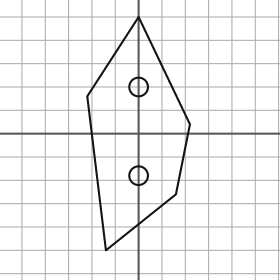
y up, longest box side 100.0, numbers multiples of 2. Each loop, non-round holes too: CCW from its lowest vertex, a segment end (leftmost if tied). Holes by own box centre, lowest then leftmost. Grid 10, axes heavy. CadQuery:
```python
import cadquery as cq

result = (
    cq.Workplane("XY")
    .moveTo(-14.0, -50.0)
    .lineTo(16.0, -26.0)
    .lineTo(22.0, 4.0)
    .lineTo(0.0, 50.0)
    .lineTo(-22.0, 16.0)
    .close()
    .moveTo(0.0, -18.0)
    .circle(4.0)
    .moveTo(0.0, 20.0)
    .circle(4.0)
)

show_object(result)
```